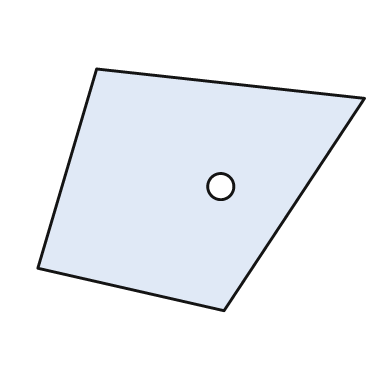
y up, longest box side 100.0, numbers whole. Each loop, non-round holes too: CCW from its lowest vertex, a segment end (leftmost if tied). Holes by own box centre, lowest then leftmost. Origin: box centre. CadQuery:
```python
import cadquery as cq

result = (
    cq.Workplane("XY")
    .moveTo(7.0, -37.0)
    .lineTo(50.0, 28.0)
    .lineTo(-32.0, 37.0)
    .lineTo(-50.0, -24.0)
    .close()
    .moveTo(6.0, 1.0)
    .circle(4.0)
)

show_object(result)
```